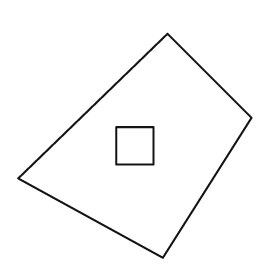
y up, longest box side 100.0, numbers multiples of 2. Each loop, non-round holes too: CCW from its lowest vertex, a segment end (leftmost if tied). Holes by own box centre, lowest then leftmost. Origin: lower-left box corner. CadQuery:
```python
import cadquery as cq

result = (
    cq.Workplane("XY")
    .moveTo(62.0, 0.0)
    .lineTo(100.0, 60.0)
    .lineTo(64.0, 96.0)
    .lineTo(0.0, 34.0)
    .close()
    .moveTo(42.0, 40.0)
    .lineTo(58.0, 40.0)
    .lineTo(58.0, 56.0)
    .lineTo(42.0, 56.0)
    .close()
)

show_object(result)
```